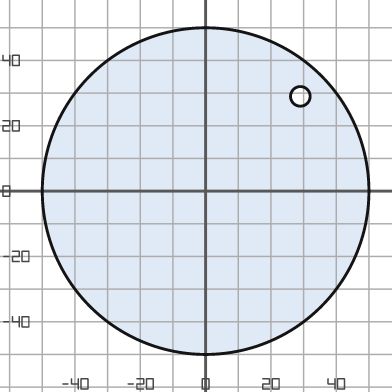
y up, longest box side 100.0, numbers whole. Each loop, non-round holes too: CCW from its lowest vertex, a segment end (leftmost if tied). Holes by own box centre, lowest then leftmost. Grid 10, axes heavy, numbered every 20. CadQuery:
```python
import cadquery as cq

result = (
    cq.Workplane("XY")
    .moveTo(0.0, 0.0)
    .circle(50.0)
    .moveTo(29.0, 29.0)
    .circle(3.0)
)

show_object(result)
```